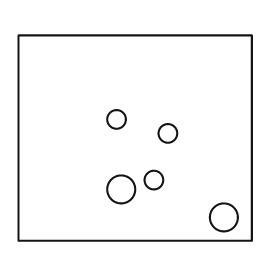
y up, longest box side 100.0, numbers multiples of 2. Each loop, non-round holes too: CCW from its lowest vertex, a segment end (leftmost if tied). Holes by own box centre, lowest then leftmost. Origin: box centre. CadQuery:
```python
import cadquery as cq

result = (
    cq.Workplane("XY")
    .moveTo(-50.0, -44.0)
    .lineTo(50.0, -44.0)
    .lineTo(50.0, 44.0)
    .lineTo(-50.0, 44.0)
    .close()
    .moveTo(38.0, -34.0)
    .circle(6.0)
    .moveTo(-6.0, -22.0)
    .circle(6.0)
    .moveTo(8.0, -18.0)
    .circle(4.0)
    .moveTo(14.0, 2.0)
    .circle(4.0)
    .moveTo(-8.0, 8.0)
    .circle(4.0)
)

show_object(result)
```